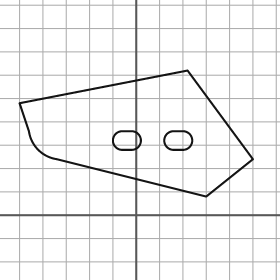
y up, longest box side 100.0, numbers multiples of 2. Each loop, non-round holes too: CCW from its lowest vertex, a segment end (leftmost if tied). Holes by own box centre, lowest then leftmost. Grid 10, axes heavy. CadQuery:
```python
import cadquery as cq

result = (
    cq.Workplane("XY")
    .moveTo(30.0, 8.0)
    .lineTo(50.0, 24.0)
    .lineTo(22.0, 62.0)
    .lineTo(-50.0, 48.0)
    .lineTo(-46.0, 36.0)
    .threePointArc((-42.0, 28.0), (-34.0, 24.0))
    .close()
    .moveTo(-6.0, 28.0)
    .lineTo(-2.0, 28.0)
    .threePointArc((2.0, 32.0), (-2.0, 36.0))
    .lineTo(-6.0, 36.0)
    .threePointArc((-10.0, 32.0), (-6.0, 28.0))
    .close()
    .moveTo(16.0, 28.0)
    .lineTo(20.0, 28.0)
    .threePointArc((24.0, 32.0), (20.0, 36.0))
    .lineTo(16.0, 36.0)
    .threePointArc((12.0, 32.0), (16.0, 28.0))
    .close()
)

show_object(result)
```